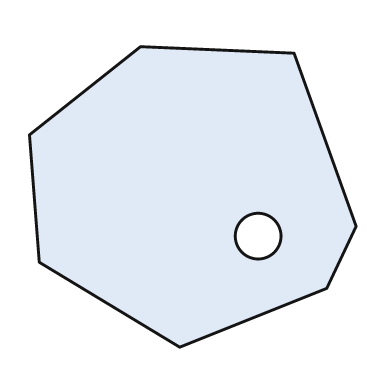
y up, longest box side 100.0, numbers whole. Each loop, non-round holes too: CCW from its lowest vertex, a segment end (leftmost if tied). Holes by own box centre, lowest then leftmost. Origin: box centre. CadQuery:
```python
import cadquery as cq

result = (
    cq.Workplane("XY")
    .moveTo(-4.0, -46.0)
    .lineTo(41.0, -28.0)
    .lineTo(50.0, -9.0)
    .lineTo(31.0, 44.0)
    .lineTo(-16.0, 46.0)
    .lineTo(-50.0, 19.0)
    .lineTo(-47.0, -20.0)
    .close()
    .moveTo(20.0, -12.0)
    .circle(7.0)
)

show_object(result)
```